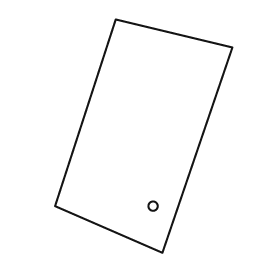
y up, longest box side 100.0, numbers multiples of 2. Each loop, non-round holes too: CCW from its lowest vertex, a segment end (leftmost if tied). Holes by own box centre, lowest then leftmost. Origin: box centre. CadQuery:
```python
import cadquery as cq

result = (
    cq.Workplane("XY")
    .moveTo(8.0, -50.0)
    .lineTo(38.0, 38.0)
    .lineTo(-12.0, 50.0)
    .lineTo(-38.0, -30.0)
    .close()
    .moveTo(4.0, -30.0)
    .circle(2.0)
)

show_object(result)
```